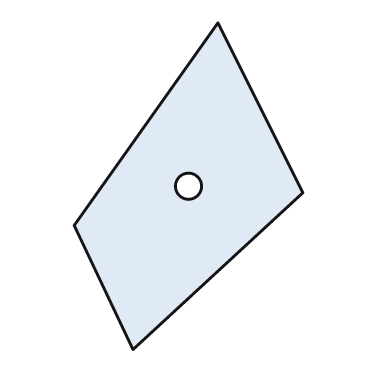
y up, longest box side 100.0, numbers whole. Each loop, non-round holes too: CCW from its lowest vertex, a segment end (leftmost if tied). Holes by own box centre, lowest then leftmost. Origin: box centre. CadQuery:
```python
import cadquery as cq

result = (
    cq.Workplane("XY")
    .moveTo(-17.0, -50.0)
    .lineTo(35.0, -2.0)
    .lineTo(9.0, 50.0)
    .lineTo(-35.0, -12.0)
    .close()
    .moveTo(0.0, 0.0)
    .circle(4.0)
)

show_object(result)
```